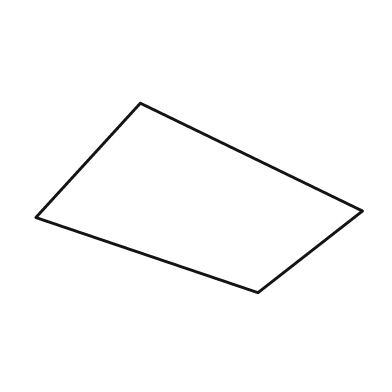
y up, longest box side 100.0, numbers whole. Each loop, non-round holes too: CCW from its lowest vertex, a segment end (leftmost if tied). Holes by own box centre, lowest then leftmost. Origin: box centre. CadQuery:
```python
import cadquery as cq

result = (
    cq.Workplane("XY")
    .moveTo(18.0, -29.0)
    .lineTo(50.0, -4.0)
    .lineTo(-18.0, 29.0)
    .lineTo(-50.0, -6.0)
    .close()
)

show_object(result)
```